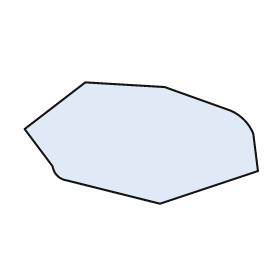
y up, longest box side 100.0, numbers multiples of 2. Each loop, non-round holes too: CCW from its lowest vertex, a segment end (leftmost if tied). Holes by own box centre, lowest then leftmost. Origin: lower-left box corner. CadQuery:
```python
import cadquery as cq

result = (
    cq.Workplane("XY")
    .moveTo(58.0, 0.0)
    .lineTo(100.0, 14.0)
    .lineTo(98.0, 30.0)
    .threePointArc((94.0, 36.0), (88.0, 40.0))
    .lineTo(60.0, 50.0)
    .lineTo(26.0, 52.0)
    .lineTo(0.0, 32.0)
    .lineTo(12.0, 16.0)
    .threePointArc((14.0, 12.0), (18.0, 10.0))
    .close()
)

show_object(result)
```